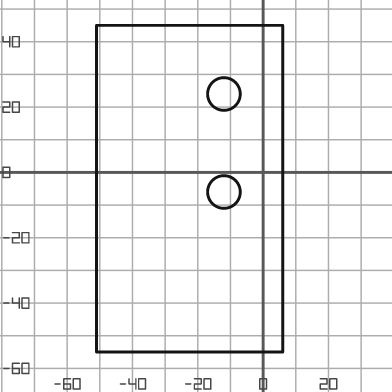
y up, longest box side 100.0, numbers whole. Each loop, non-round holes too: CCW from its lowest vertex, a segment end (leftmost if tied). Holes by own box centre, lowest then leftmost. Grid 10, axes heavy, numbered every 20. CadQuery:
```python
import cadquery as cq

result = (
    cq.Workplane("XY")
    .moveTo(-51.0, -55.0)
    .lineTo(6.0, -55.0)
    .lineTo(6.0, 45.0)
    .lineTo(-51.0, 45.0)
    .close()
    .moveTo(-12.0, -6.0)
    .circle(5.0)
    .moveTo(-12.0, 24.0)
    .circle(5.0)
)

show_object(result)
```